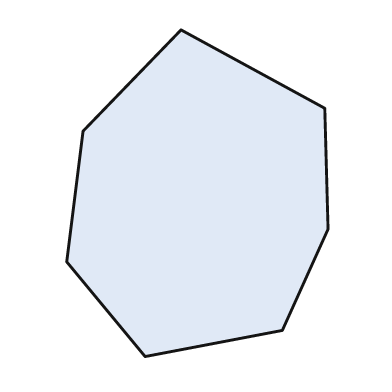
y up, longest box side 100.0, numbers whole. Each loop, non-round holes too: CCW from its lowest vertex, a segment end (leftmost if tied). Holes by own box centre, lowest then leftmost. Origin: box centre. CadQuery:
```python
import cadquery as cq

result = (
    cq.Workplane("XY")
    .moveTo(-16.0, -50.0)
    .lineTo(26.0, -42.0)
    .lineTo(40.0, -11.0)
    .lineTo(39.0, 26.0)
    .lineTo(-5.0, 50.0)
    .lineTo(-35.0, 19.0)
    .lineTo(-40.0, -21.0)
    .close()
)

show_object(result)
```